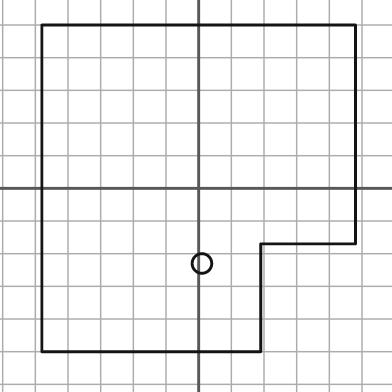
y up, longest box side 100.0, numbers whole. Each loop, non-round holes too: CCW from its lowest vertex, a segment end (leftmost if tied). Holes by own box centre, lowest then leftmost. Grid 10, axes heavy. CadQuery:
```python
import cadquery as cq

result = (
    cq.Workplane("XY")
    .moveTo(-48.0, -50.0)
    .lineTo(19.0, -50.0)
    .lineTo(19.0, -17.0)
    .lineTo(48.0, -17.0)
    .lineTo(48.0, 50.0)
    .lineTo(-48.0, 50.0)
    .close()
    .moveTo(1.0, -23.0)
    .circle(3.0)
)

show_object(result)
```